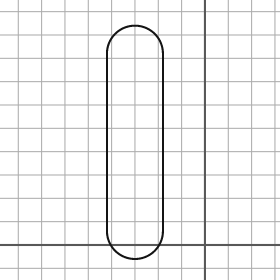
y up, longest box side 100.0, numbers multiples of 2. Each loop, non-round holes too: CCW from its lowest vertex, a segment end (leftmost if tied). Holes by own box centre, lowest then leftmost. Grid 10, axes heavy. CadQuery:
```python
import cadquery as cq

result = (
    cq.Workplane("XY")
    .moveTo(-42.0, 6.0)
    .threePointArc((-30.0, -6.0), (-18.0, 6.0))
    .lineTo(-18.0, 82.0)
    .threePointArc((-30.0, 94.0), (-42.0, 82.0))
    .close()
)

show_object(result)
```